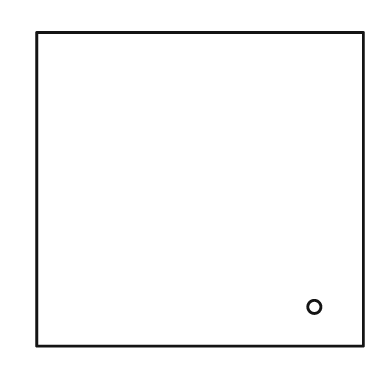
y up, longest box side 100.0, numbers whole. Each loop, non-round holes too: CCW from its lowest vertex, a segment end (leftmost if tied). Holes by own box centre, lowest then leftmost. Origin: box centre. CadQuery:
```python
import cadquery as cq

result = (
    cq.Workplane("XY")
    .moveTo(-50.0, -48.0)
    .lineTo(50.0, -48.0)
    .lineTo(50.0, 48.0)
    .lineTo(-50.0, 48.0)
    .close()
    .moveTo(35.0, -36.0)
    .circle(2.0)
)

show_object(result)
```